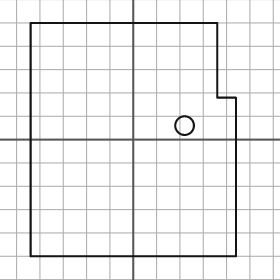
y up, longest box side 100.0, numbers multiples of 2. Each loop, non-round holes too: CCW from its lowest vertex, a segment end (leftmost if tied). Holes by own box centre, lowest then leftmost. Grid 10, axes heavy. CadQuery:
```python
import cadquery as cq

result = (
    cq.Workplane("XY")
    .moveTo(-44.0, -50.0)
    .lineTo(44.0, -50.0)
    .lineTo(44.0, 18.0)
    .lineTo(36.0, 18.0)
    .lineTo(36.0, 50.0)
    .lineTo(-44.0, 50.0)
    .close()
    .moveTo(22.0, 6.0)
    .circle(4.0)
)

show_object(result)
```